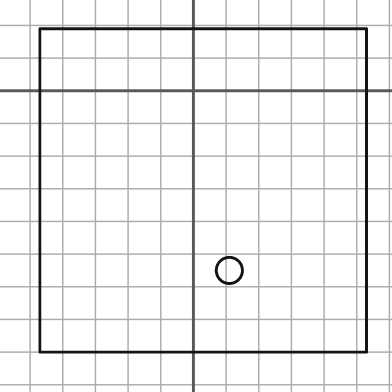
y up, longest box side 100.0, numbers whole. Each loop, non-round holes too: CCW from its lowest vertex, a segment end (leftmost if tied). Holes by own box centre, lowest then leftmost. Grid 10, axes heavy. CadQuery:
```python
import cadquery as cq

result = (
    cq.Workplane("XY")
    .moveTo(-47.0, -80.0)
    .lineTo(53.0, -80.0)
    .lineTo(53.0, 19.0)
    .lineTo(-47.0, 19.0)
    .close()
    .moveTo(11.0, -55.0)
    .circle(4.0)
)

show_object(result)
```